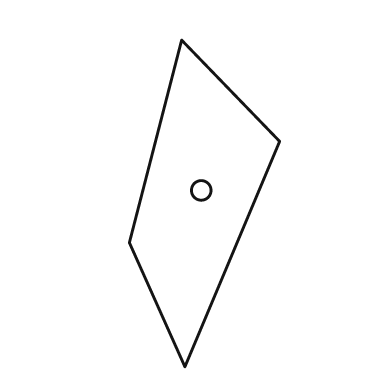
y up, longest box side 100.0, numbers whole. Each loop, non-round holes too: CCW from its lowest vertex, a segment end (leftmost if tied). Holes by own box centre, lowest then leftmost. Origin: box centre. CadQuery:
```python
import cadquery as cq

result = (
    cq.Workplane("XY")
    .moveTo(-6.0, -50.0)
    .lineTo(23.0, 19.0)
    .lineTo(-7.0, 50.0)
    .lineTo(-23.0, -12.0)
    .close()
    .moveTo(-1.0, 4.0)
    .circle(3.0)
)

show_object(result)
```